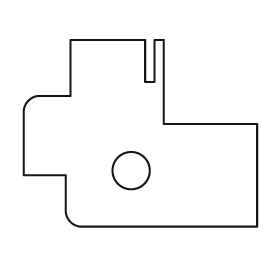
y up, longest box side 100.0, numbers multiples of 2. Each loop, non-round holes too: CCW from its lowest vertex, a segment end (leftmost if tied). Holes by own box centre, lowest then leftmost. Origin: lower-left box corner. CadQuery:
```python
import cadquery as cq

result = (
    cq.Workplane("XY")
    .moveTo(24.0, 0.0)
    .lineTo(100.0, 0.0)
    .lineTo(100.0, 44.0)
    .lineTo(60.0, 44.0)
    .lineTo(60.0, 80.0)
    .lineTo(56.0, 80.0)
    .lineTo(56.0, 62.0)
    .lineTo(52.0, 62.0)
    .lineTo(52.0, 80.0)
    .lineTo(20.0, 80.0)
    .lineTo(20.0, 56.0)
    .lineTo(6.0, 56.0)
    .threePointArc((2.0, 54.0), (0.0, 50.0))
    .lineTo(0.0, 22.0)
    .lineTo(18.0, 22.0)
    .lineTo(18.0, 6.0)
    .threePointArc((20.0, 2.0), (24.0, 0.0))
    .close()
    .moveTo(46.0, 24.0)
    .circle(8.0)
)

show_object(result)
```